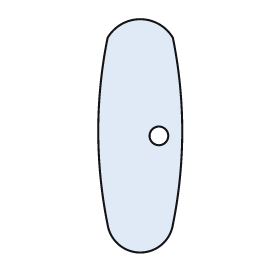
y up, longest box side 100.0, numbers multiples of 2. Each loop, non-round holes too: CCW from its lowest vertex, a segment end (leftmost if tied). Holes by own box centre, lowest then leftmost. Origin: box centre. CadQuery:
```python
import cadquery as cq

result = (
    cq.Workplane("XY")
    .moveTo(-14.0, -38.0)
    .threePointArc((0.0, -50.0), (14.0, -38.0))
    .threePointArc((18.0, 2.0), (14.0, 42.0))
    .threePointArc((0.0, 50.0), (-14.0, 42.0))
    .threePointArc((-18.0, 2.0), (-14.0, -38.0))
    .close()
    .moveTo(8.0, 0.0)
    .circle(4.0)
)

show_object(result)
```